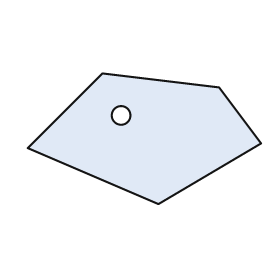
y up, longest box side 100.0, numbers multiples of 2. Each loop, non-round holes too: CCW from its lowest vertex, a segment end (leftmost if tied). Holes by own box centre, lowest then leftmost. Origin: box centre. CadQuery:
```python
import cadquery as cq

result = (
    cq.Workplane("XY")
    .moveTo(6.0, -28.0)
    .lineTo(50.0, -2.0)
    .lineTo(32.0, 22.0)
    .lineTo(-18.0, 28.0)
    .lineTo(-50.0, -4.0)
    .close()
    .moveTo(-10.0, 10.0)
    .circle(4.0)
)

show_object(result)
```